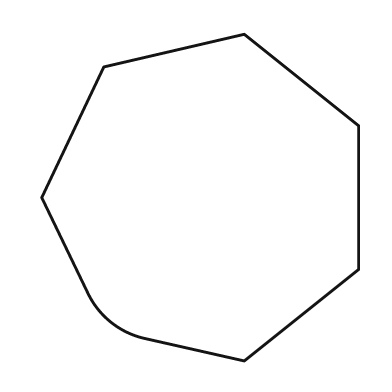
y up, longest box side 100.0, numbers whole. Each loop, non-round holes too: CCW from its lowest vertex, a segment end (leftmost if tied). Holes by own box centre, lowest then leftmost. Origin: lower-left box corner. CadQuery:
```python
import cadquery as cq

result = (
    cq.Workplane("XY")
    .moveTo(62.0, 0.0)
    .lineTo(97.0, 28.0)
    .lineTo(97.0, 72.0)
    .lineTo(62.0, 100.0)
    .lineTo(19.0, 90.0)
    .lineTo(0.0, 50.0)
    .lineTo(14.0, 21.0)
    .threePointArc((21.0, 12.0), (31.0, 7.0))
    .close()
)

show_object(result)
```